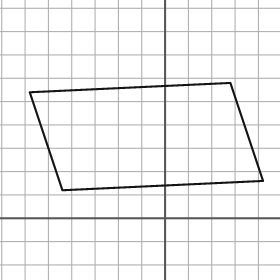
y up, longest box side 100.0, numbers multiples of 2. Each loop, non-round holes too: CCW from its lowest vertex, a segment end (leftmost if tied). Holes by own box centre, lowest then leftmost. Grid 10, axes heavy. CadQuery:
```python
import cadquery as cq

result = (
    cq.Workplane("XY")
    .moveTo(-44.0, 12.0)
    .lineTo(42.0, 16.0)
    .lineTo(28.0, 58.0)
    .lineTo(-58.0, 54.0)
    .close()
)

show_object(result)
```